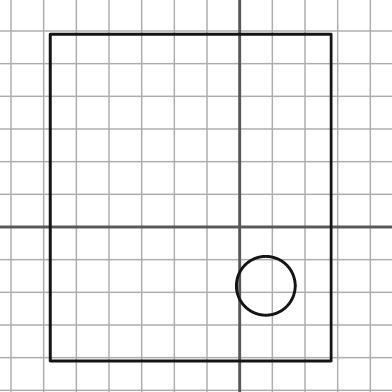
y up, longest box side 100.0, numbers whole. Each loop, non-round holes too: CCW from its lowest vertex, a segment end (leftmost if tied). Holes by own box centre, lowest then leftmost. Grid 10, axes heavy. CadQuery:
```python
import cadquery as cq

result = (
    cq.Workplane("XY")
    .moveTo(-58.0, -41.0)
    .lineTo(28.0, -41.0)
    .lineTo(28.0, 59.0)
    .lineTo(-58.0, 59.0)
    .close()
    .moveTo(8.0, -18.0)
    .circle(9.0)
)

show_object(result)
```